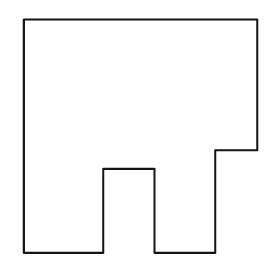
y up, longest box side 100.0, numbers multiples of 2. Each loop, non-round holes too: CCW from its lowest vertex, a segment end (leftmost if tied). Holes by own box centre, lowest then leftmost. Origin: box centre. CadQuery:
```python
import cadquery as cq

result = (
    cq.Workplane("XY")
    .moveTo(-50.0, -50.0)
    .lineTo(-16.0, -50.0)
    .lineTo(-16.0, -14.0)
    .lineTo(6.0, -14.0)
    .lineTo(6.0, -50.0)
    .lineTo(32.0, -50.0)
    .lineTo(32.0, -6.0)
    .lineTo(50.0, -6.0)
    .lineTo(50.0, 50.0)
    .lineTo(-50.0, 50.0)
    .close()
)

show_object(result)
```